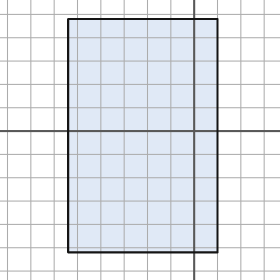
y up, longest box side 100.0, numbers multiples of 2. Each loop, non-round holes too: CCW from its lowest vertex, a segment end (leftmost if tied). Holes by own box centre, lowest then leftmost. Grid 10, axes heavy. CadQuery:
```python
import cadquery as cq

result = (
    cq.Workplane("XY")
    .moveTo(-54.0, -52.0)
    .lineTo(10.0, -52.0)
    .lineTo(10.0, 48.0)
    .lineTo(-54.0, 48.0)
    .close()
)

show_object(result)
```